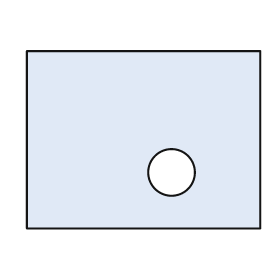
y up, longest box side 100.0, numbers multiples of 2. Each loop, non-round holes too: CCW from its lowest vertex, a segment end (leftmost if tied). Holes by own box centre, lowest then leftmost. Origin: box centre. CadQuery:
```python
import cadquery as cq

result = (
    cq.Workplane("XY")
    .moveTo(-50.0, -38.0)
    .lineTo(50.0, -38.0)
    .lineTo(50.0, 38.0)
    .lineTo(-50.0, 38.0)
    .close()
    .moveTo(12.0, -14.0)
    .circle(10.0)
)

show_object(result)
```